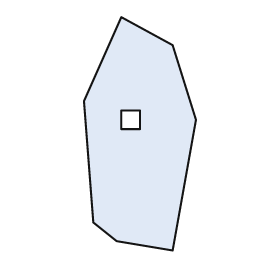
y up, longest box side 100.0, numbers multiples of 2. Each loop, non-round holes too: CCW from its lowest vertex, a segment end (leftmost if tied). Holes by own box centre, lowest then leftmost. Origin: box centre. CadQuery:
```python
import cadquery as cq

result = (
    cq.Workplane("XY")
    .moveTo(14.0, -50.0)
    .lineTo(24.0, 6.0)
    .lineTo(14.0, 38.0)
    .lineTo(-8.0, 50.0)
    .lineTo(-24.0, 14.0)
    .lineTo(-20.0, -38.0)
    .lineTo(-10.0, -46.0)
    .close()
    .moveTo(-8.0, 2.0)
    .lineTo(0.0, 2.0)
    .lineTo(0.0, 10.0)
    .lineTo(-8.0, 10.0)
    .close()
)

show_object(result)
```